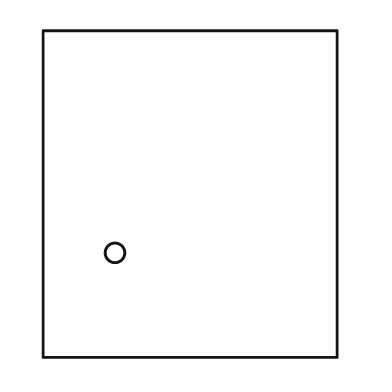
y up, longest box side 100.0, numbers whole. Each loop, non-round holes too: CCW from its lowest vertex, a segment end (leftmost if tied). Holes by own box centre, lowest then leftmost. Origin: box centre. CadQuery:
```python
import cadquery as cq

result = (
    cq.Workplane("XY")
    .moveTo(-45.0, -50.0)
    .lineTo(45.0, -50.0)
    .lineTo(45.0, 50.0)
    .lineTo(-45.0, 50.0)
    .close()
    .moveTo(-23.0, -18.0)
    .circle(3.0)
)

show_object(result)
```